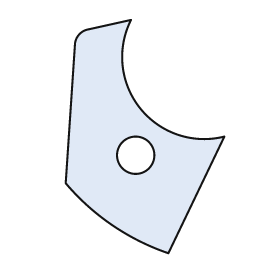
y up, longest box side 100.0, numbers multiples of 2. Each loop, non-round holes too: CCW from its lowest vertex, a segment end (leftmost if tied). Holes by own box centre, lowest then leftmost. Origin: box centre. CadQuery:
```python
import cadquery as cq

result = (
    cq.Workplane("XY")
    .moveTo(10.0, -50.0)
    .lineTo(34.0, 0.0)
    .threePointArc((-2.0, 12.0), (-6.0, 50.0))
    .lineTo(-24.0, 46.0)
    .threePointArc((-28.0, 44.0), (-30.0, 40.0))
    .lineTo(-34.0, -20.0)
    .threePointArc((-14.0, -38.0), (10.0, -50.0))
    .close()
    .moveTo(-4.0, -8.0)
    .circle(8.0)
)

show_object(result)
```